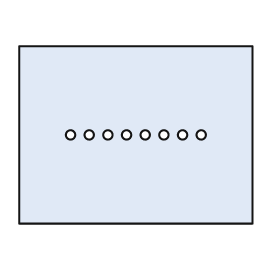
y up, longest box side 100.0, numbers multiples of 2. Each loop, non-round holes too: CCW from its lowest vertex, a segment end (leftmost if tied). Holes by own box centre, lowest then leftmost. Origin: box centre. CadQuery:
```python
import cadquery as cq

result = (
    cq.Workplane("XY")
    .moveTo(-50.0, -38.0)
    .lineTo(50.0, -38.0)
    .lineTo(50.0, 38.0)
    .lineTo(-50.0, 38.0)
    .close()
    .moveTo(-28.0, 0.0)
    .circle(2.0)
    .moveTo(-20.0, 0.0)
    .circle(2.0)
    .moveTo(-12.0, 0.0)
    .circle(2.0)
    .moveTo(-4.0, 0.0)
    .circle(2.0)
    .moveTo(4.0, 0.0)
    .circle(2.0)
    .moveTo(12.0, 0.0)
    .circle(2.0)
    .moveTo(20.0, 0.0)
    .circle(2.0)
    .moveTo(28.0, 0.0)
    .circle(2.0)
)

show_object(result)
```